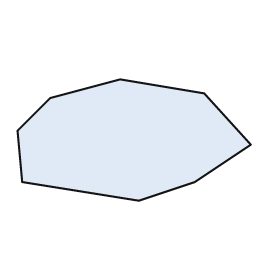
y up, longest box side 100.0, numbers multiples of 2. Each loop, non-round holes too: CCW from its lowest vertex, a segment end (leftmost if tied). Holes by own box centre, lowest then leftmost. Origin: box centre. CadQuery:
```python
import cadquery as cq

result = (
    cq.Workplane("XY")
    .moveTo(2.0, -26.0)
    .lineTo(26.0, -18.0)
    .lineTo(50.0, -2.0)
    .lineTo(30.0, 20.0)
    .lineTo(-6.0, 26.0)
    .lineTo(-36.0, 18.0)
    .lineTo(-50.0, 4.0)
    .lineTo(-48.0, -18.0)
    .close()
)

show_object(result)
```